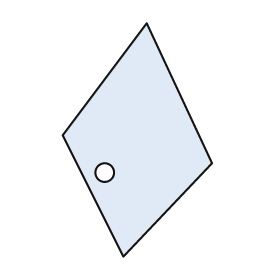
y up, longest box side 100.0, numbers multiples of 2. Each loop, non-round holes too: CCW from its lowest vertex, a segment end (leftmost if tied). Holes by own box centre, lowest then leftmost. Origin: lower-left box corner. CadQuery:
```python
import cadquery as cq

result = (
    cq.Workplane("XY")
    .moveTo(26.0, 0.0)
    .lineTo(64.0, 40.0)
    .lineTo(36.0, 100.0)
    .lineTo(0.0, 52.0)
    .close()
    .moveTo(18.0, 36.0)
    .circle(4.0)
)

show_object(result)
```